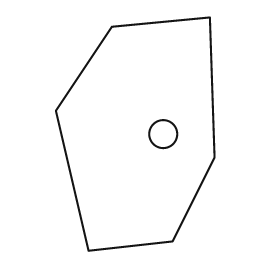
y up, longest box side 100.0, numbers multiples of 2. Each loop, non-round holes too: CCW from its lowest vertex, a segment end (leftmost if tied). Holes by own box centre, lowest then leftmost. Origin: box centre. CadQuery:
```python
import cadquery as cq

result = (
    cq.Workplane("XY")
    .moveTo(-20.0, -50.0)
    .lineTo(16.0, -46.0)
    .lineTo(34.0, -10.0)
    .lineTo(32.0, 50.0)
    .lineTo(-10.0, 46.0)
    .lineTo(-34.0, 10.0)
    .close()
    .moveTo(12.0, 0.0)
    .circle(6.0)
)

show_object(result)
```